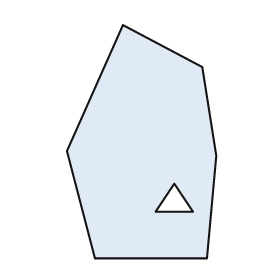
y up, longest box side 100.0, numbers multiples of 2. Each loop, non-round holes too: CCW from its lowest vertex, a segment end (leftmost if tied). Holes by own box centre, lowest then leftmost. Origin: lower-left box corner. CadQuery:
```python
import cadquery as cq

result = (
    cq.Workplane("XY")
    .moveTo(12.0, 0.0)
    .lineTo(60.0, 0.0)
    .lineTo(64.0, 44.0)
    .lineTo(58.0, 82.0)
    .lineTo(24.0, 100.0)
    .lineTo(0.0, 46.0)
    .close()
    .moveTo(38.0, 20.0)
    .lineTo(54.0, 20.0)
    .lineTo(46.0, 32.0)
    .close()
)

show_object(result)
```